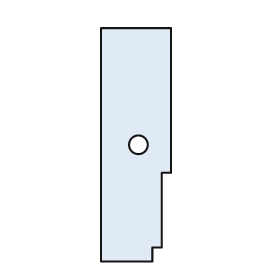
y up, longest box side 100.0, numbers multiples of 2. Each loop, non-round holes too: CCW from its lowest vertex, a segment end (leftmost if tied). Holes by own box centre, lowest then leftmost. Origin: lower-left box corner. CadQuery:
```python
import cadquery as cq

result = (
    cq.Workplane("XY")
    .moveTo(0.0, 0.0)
    .lineTo(22.0, 0.0)
    .lineTo(22.0, 6.0)
    .lineTo(26.0, 6.0)
    .lineTo(26.0, 38.0)
    .lineTo(30.0, 38.0)
    .lineTo(30.0, 100.0)
    .lineTo(0.0, 100.0)
    .close()
    .moveTo(16.0, 50.0)
    .circle(4.0)
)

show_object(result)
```